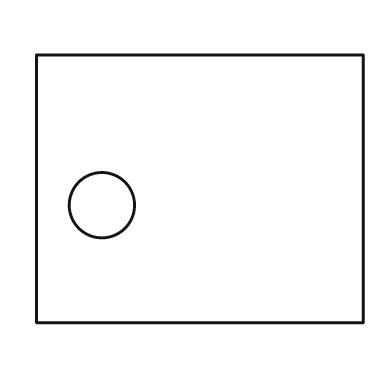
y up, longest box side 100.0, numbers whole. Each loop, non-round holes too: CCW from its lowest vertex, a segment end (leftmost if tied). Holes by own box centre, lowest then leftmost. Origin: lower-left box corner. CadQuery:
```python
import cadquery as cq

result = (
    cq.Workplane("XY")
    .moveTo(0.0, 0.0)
    .lineTo(100.0, 0.0)
    .lineTo(100.0, 82.0)
    .lineTo(0.0, 82.0)
    .close()
    .moveTo(20.0, 36.0)
    .circle(10.0)
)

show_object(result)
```